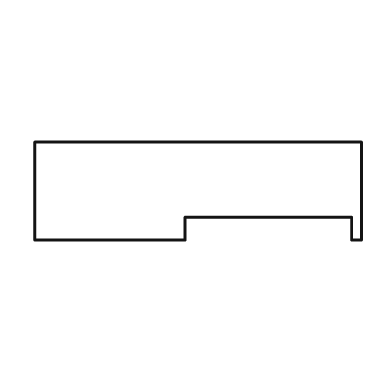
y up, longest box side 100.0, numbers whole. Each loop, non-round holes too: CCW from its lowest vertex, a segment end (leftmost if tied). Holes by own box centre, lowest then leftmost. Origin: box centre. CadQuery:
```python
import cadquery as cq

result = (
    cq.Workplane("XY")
    .moveTo(-50.0, -15.0)
    .lineTo(-4.0, -15.0)
    .lineTo(-4.0, -8.0)
    .lineTo(47.0, -8.0)
    .lineTo(47.0, -15.0)
    .lineTo(50.0, -15.0)
    .lineTo(50.0, 15.0)
    .lineTo(-50.0, 15.0)
    .close()
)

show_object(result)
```